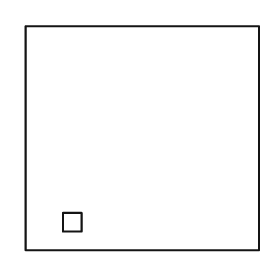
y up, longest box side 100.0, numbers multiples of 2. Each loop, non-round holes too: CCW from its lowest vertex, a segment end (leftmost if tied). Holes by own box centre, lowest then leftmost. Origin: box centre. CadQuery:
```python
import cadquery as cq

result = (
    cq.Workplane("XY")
    .moveTo(-50.0, -48.0)
    .lineTo(50.0, -48.0)
    .lineTo(50.0, 48.0)
    .lineTo(-50.0, 48.0)
    .close()
    .moveTo(-34.0, -40.0)
    .lineTo(-26.0, -40.0)
    .lineTo(-26.0, -32.0)
    .lineTo(-34.0, -32.0)
    .close()
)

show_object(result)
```